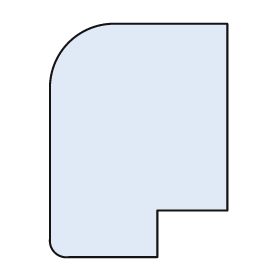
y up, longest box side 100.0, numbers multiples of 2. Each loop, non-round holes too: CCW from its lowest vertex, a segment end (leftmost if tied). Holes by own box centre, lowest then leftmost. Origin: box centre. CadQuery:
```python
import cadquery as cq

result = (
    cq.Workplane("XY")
    .moveTo(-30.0, -50.0)
    .lineTo(8.0, -50.0)
    .lineTo(8.0, -30.0)
    .lineTo(38.0, -30.0)
    .lineTo(38.0, 50.0)
    .lineTo(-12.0, 50.0)
    .threePointArc((-30.0, 42.0), (-38.0, 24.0))
    .lineTo(-38.0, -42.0)
    .threePointArc((-36.0, -48.0), (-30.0, -50.0))
    .close()
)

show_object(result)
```